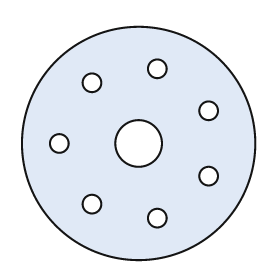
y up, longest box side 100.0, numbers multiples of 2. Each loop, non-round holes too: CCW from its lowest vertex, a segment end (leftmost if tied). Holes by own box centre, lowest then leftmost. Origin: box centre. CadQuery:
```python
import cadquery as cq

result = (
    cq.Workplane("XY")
    .moveTo(0.0, 0.0)
    .circle(50.0)
    .moveTo(8.0, -32.0)
    .circle(4.0)
    .moveTo(-20.0, -26.0)
    .circle(4.0)
    .moveTo(30.0, -14.0)
    .circle(4.0)
    .moveTo(-34.0, 0.0)
    .circle(4.0)
    .moveTo(0.0, 0.0)
    .circle(10.0)
    .moveTo(30.0, 14.0)
    .circle(4.0)
    .moveTo(-20.0, 26.0)
    .circle(4.0)
    .moveTo(8.0, 32.0)
    .circle(4.0)
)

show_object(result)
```